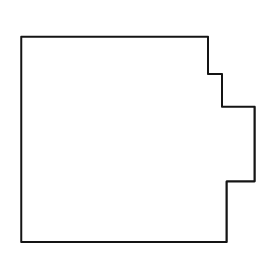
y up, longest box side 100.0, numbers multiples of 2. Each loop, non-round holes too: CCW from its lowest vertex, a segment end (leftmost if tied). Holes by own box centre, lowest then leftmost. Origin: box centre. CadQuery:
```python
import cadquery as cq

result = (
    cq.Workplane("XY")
    .moveTo(-50.0, -44.0)
    .lineTo(38.0, -44.0)
    .lineTo(38.0, -18.0)
    .lineTo(50.0, -18.0)
    .lineTo(50.0, 14.0)
    .lineTo(36.0, 14.0)
    .lineTo(36.0, 28.0)
    .lineTo(30.0, 28.0)
    .lineTo(30.0, 44.0)
    .lineTo(-50.0, 44.0)
    .close()
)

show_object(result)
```